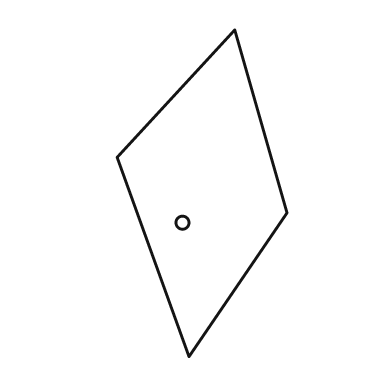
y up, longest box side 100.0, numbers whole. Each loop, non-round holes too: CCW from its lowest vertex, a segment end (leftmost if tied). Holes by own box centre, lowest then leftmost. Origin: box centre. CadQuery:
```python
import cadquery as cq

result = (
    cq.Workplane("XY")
    .moveTo(-4.0, -50.0)
    .lineTo(26.0, -6.0)
    .lineTo(10.0, 50.0)
    .lineTo(-26.0, 11.0)
    .close()
    .moveTo(-6.0, -9.0)
    .circle(2.0)
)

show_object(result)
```